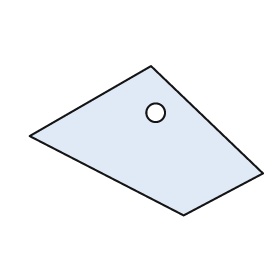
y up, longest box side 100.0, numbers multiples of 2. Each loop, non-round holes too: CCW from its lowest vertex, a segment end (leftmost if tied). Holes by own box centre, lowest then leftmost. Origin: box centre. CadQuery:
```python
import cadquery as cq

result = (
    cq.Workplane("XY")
    .moveTo(16.0, -32.0)
    .lineTo(50.0, -14.0)
    .lineTo(2.0, 32.0)
    .lineTo(-50.0, 2.0)
    .close()
    .moveTo(4.0, 12.0)
    .circle(4.0)
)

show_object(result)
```